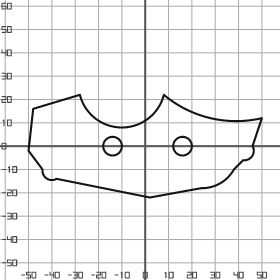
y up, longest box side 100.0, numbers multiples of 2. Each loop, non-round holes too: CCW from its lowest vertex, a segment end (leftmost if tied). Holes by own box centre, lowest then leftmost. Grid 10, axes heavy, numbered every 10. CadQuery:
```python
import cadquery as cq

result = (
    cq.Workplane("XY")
    .moveTo(2.0, -22.0)
    .lineTo(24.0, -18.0)
    .threePointArc((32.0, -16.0), (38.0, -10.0))
    .lineTo(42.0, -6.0)
    .threePointArc((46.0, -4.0), (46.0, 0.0))
    .lineTo(50.0, 12.0)
    .threePointArc((28.0, 12.0), (8.0, 22.0))
    .threePointArc((-10.0, 8.0), (-28.0, 22.0))
    .lineTo(-48.0, 16.0)
    .lineTo(-50.0, -2.0)
    .lineTo(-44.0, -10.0)
    .threePointArc((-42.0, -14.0), (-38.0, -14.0))
    .close()
    .moveTo(-14.0, 0.0)
    .circle(4.0)
    .moveTo(16.0, 0.0)
    .circle(4.0)
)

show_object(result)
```